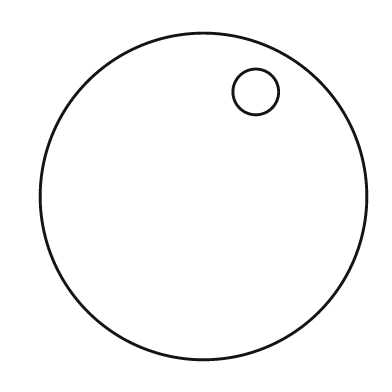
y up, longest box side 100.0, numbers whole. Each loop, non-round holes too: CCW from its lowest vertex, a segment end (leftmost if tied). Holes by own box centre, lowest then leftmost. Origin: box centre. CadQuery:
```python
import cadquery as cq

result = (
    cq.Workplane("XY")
    .moveTo(0.0, 0.0)
    .circle(50.0)
    .moveTo(16.0, 32.0)
    .circle(7.0)
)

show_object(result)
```